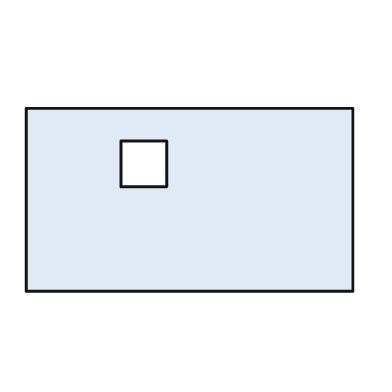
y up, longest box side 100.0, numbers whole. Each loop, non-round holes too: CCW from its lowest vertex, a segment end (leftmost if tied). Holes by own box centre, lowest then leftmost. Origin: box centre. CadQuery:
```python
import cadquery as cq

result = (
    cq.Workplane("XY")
    .moveTo(-50.0, -28.0)
    .lineTo(50.0, -28.0)
    .lineTo(50.0, 28.0)
    .lineTo(-50.0, 28.0)
    .close()
    .moveTo(-21.0, 4.0)
    .lineTo(-7.0, 4.0)
    .lineTo(-7.0, 18.0)
    .lineTo(-21.0, 18.0)
    .close()
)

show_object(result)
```